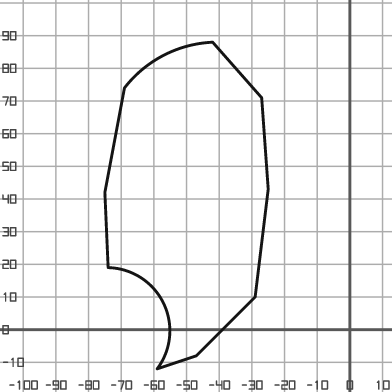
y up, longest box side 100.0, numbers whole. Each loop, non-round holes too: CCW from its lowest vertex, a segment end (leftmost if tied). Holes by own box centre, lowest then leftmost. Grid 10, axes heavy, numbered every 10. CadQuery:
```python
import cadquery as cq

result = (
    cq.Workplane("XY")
    .moveTo(-59.0, -12.0)
    .lineTo(-47.0, -8.0)
    .lineTo(-29.0, 10.0)
    .lineTo(-25.0, 43.0)
    .lineTo(-27.0, 71.0)
    .lineTo(-42.0, 88.0)
    .threePointArc((-57.0, 84.0), (-69.0, 74.0))
    .lineTo(-75.0, 42.0)
    .lineTo(-74.0, 19.0)
    .threePointArc((-57.0, 8.0), (-59.0, -12.0))
    .close()
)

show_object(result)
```